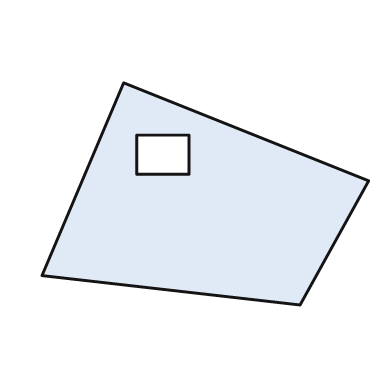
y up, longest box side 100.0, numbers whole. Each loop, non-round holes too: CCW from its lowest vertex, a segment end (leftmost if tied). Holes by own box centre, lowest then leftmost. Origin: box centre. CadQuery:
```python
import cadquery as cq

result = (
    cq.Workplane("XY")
    .moveTo(29.0, -34.0)
    .lineTo(50.0, 4.0)
    .lineTo(-25.0, 34.0)
    .lineTo(-50.0, -25.0)
    .close()
    .moveTo(-21.0, 6.0)
    .lineTo(-5.0, 6.0)
    .lineTo(-5.0, 18.0)
    .lineTo(-21.0, 18.0)
    .close()
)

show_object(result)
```